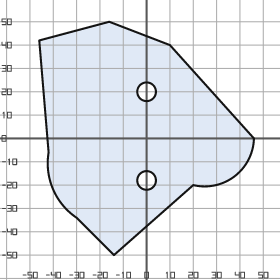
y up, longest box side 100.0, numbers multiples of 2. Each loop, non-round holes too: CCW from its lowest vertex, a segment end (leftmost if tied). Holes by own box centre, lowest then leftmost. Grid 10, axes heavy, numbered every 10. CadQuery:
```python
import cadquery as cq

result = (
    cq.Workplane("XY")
    .moveTo(-14.0, -50.0)
    .lineTo(20.0, -20.0)
    .threePointArc((38.0, -16.0), (46.0, 0.0))
    .lineTo(10.0, 40.0)
    .lineTo(-16.0, 50.0)
    .lineTo(-46.0, 42.0)
    .lineTo(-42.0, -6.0)
    .threePointArc((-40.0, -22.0), (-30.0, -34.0))
    .close()
    .moveTo(0.0, -18.0)
    .circle(4.0)
    .moveTo(0.0, 20.0)
    .circle(4.0)
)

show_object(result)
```